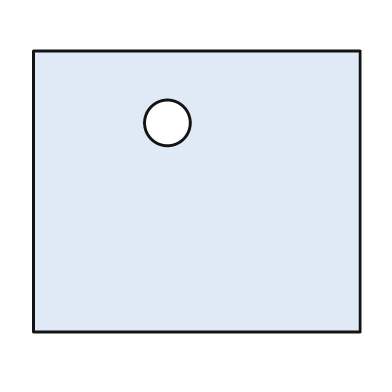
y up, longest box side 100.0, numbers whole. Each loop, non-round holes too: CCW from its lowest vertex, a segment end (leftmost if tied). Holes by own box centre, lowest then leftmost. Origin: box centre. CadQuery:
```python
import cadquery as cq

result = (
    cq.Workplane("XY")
    .moveTo(-50.0, -43.0)
    .lineTo(50.0, -43.0)
    .lineTo(50.0, 43.0)
    .lineTo(-50.0, 43.0)
    .close()
    .moveTo(-9.0, 21.0)
    .circle(7.0)
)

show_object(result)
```